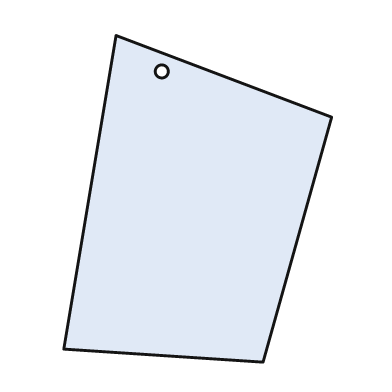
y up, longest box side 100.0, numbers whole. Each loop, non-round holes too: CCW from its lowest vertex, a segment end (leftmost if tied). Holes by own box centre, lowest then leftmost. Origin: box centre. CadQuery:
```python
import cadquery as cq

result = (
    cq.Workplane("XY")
    .moveTo(20.0, -50.0)
    .lineTo(41.0, 25.0)
    .lineTo(-25.0, 50.0)
    .lineTo(-41.0, -46.0)
    .close()
    .moveTo(-11.0, 39.0)
    .circle(2.0)
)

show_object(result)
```